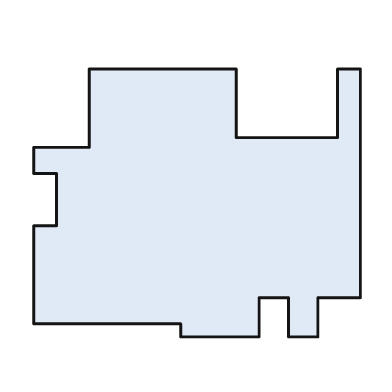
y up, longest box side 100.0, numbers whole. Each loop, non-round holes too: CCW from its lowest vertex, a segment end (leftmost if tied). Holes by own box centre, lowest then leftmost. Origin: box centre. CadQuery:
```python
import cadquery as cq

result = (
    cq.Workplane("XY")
    .moveTo(-5.0, -41.0)
    .lineTo(19.0, -41.0)
    .lineTo(19.0, -29.0)
    .lineTo(28.0, -29.0)
    .lineTo(28.0, -41.0)
    .lineTo(37.0, -41.0)
    .lineTo(37.0, -29.0)
    .lineTo(50.0, -29.0)
    .lineTo(50.0, 41.0)
    .lineTo(43.0, 41.0)
    .lineTo(43.0, 20.0)
    .lineTo(12.0, 20.0)
    .lineTo(12.0, 41.0)
    .lineTo(-33.0, 41.0)
    .lineTo(-33.0, 17.0)
    .lineTo(-50.0, 17.0)
    .lineTo(-50.0, 9.0)
    .lineTo(-43.0, 9.0)
    .lineTo(-43.0, -7.0)
    .lineTo(-50.0, -7.0)
    .lineTo(-50.0, -37.0)
    .lineTo(-5.0, -37.0)
    .close()
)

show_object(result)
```